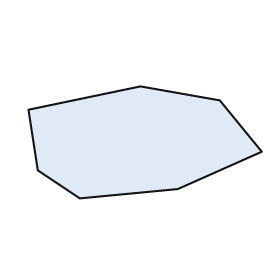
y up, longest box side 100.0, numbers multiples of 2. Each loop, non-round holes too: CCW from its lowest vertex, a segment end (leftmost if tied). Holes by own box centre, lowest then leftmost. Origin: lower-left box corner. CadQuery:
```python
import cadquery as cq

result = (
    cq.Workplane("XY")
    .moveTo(22.0, 0.0)
    .lineTo(64.0, 4.0)
    .lineTo(100.0, 20.0)
    .lineTo(82.0, 42.0)
    .lineTo(48.0, 48.0)
    .lineTo(0.0, 38.0)
    .lineTo(4.0, 12.0)
    .close()
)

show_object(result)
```